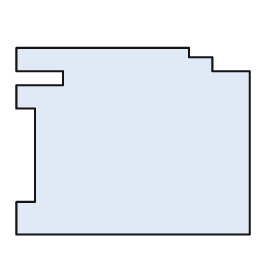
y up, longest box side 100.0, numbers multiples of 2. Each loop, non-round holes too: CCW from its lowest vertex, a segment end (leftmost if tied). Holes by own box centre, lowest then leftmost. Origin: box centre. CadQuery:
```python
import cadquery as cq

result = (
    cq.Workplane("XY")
    .moveTo(-50.0, -40.0)
    .lineTo(50.0, -40.0)
    .lineTo(50.0, 30.0)
    .lineTo(34.0, 30.0)
    .lineTo(34.0, 36.0)
    .lineTo(24.0, 36.0)
    .lineTo(24.0, 40.0)
    .lineTo(-50.0, 40.0)
    .lineTo(-50.0, 30.0)
    .lineTo(-30.0, 30.0)
    .lineTo(-30.0, 24.0)
    .lineTo(-50.0, 24.0)
    .lineTo(-50.0, 14.0)
    .lineTo(-42.0, 14.0)
    .lineTo(-42.0, -26.0)
    .lineTo(-50.0, -26.0)
    .close()
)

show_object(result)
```